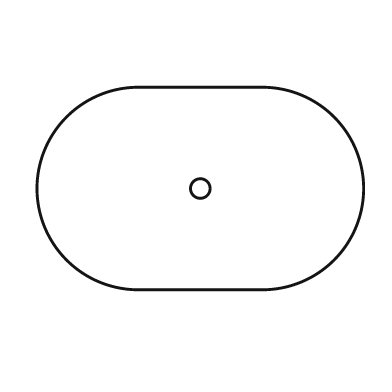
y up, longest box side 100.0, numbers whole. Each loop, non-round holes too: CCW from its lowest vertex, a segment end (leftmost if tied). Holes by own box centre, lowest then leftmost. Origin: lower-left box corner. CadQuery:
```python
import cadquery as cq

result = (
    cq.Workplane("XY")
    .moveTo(31.0, 0.0)
    .lineTo(69.0, 0.0)
    .threePointArc((100.0, 31.0), (69.0, 62.0))
    .lineTo(31.0, 62.0)
    .threePointArc((0.0, 31.0), (31.0, 0.0))
    .close()
    .moveTo(50.0, 31.0)
    .circle(3.0)
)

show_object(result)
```